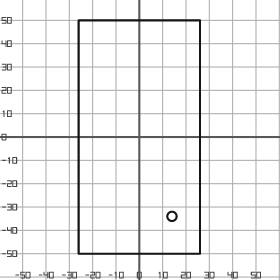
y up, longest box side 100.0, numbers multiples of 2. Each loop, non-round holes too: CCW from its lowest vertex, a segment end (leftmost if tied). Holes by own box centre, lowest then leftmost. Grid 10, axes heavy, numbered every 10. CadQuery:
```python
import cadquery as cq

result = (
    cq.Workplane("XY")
    .moveTo(-26.0, -50.0)
    .lineTo(26.0, -50.0)
    .lineTo(26.0, 50.0)
    .lineTo(-26.0, 50.0)
    .close()
    .moveTo(14.0, -34.0)
    .circle(2.0)
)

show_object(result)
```